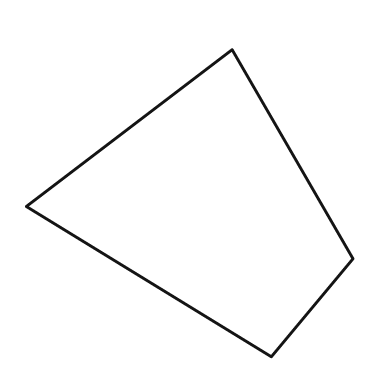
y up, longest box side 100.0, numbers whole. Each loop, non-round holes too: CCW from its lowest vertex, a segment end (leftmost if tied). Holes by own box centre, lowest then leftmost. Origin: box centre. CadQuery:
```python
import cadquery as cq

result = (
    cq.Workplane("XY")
    .moveTo(25.0, -47.0)
    .lineTo(50.0, -17.0)
    .lineTo(13.0, 47.0)
    .lineTo(-50.0, -1.0)
    .close()
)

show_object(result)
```